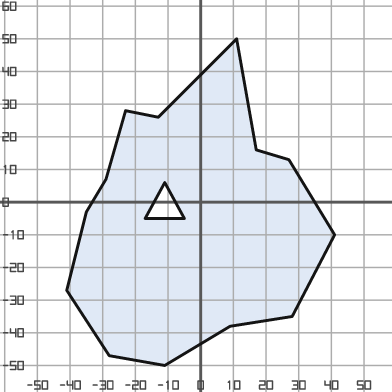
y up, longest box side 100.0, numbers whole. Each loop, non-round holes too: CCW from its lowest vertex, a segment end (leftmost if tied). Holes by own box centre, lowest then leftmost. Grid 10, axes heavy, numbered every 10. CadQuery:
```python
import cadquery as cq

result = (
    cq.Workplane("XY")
    .moveTo(-11.0, -50.0)
    .lineTo(9.0, -38.0)
    .lineTo(28.0, -35.0)
    .lineTo(41.0, -10.0)
    .lineTo(27.0, 13.0)
    .lineTo(17.0, 16.0)
    .lineTo(11.0, 50.0)
    .lineTo(-13.0, 26.0)
    .lineTo(-23.0, 28.0)
    .lineTo(-29.0, 7.0)
    .lineTo(-35.0, -3.0)
    .lineTo(-41.0, -27.0)
    .lineTo(-28.0, -47.0)
    .close()
    .moveTo(-17.0, -5.0)
    .lineTo(-5.0, -5.0)
    .lineTo(-11.0, 6.0)
    .close()
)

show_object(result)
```